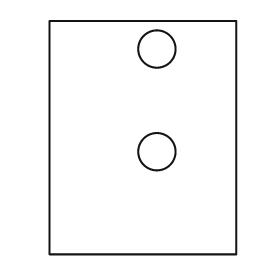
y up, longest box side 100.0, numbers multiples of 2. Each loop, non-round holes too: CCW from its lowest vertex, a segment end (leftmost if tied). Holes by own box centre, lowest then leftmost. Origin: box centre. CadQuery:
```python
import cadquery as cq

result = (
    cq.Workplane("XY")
    .moveTo(-40.0, -50.0)
    .lineTo(40.0, -50.0)
    .lineTo(40.0, 50.0)
    .lineTo(-40.0, 50.0)
    .close()
    .moveTo(6.0, -6.0)
    .circle(8.0)
    .moveTo(6.0, 38.0)
    .circle(8.0)
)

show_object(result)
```